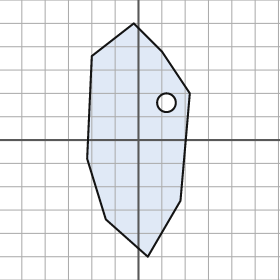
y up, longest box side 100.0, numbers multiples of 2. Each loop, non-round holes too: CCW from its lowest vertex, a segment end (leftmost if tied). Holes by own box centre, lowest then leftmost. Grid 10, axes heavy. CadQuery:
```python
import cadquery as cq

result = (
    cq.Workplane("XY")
    .moveTo(4.0, -50.0)
    .lineTo(18.0, -26.0)
    .lineTo(22.0, 20.0)
    .lineTo(10.0, 38.0)
    .lineTo(-2.0, 50.0)
    .lineTo(-20.0, 36.0)
    .lineTo(-22.0, -8.0)
    .lineTo(-14.0, -34.0)
    .close()
    .moveTo(12.0, 16.0)
    .circle(4.0)
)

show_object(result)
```